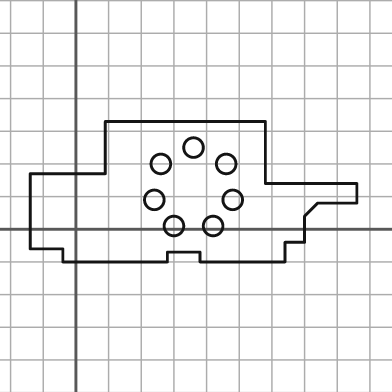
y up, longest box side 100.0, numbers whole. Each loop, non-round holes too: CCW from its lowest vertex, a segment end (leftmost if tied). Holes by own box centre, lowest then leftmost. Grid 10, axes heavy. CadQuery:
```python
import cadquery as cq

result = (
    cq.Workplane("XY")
    .moveTo(-4.0, -10.0)
    .lineTo(28.0, -10.0)
    .lineTo(28.0, -7.0)
    .lineTo(38.0, -7.0)
    .lineTo(38.0, -10.0)
    .lineTo(64.0, -10.0)
    .lineTo(64.0, -4.0)
    .lineTo(70.0, -4.0)
    .lineTo(70.0, 4.0)
    .lineTo(74.0, 8.0)
    .lineTo(86.0, 8.0)
    .lineTo(86.0, 14.0)
    .lineTo(58.0, 14.0)
    .lineTo(58.0, 33.0)
    .lineTo(9.0, 33.0)
    .lineTo(9.0, 17.0)
    .lineTo(-14.0, 17.0)
    .lineTo(-14.0, -6.0)
    .lineTo(-4.0, -6.0)
    .close()
    .moveTo(30.0, 1.0)
    .circle(3.0)
    .moveTo(42.0, 1.0)
    .circle(3.0)
    .moveTo(24.0, 9.0)
    .circle(3.0)
    .moveTo(48.0, 9.0)
    .circle(3.0)
    .moveTo(26.0, 20.0)
    .circle(3.0)
    .moveTo(46.0, 20.0)
    .circle(3.0)
    .moveTo(36.0, 25.0)
    .circle(3.0)
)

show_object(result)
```